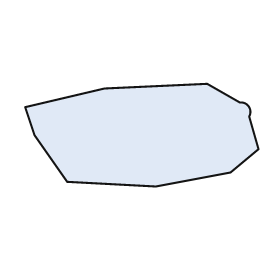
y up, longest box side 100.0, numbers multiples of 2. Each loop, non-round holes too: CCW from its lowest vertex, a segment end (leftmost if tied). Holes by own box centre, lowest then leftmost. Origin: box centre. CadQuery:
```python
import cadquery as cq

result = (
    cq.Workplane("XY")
    .moveTo(6.0, -22.0)
    .lineTo(38.0, -16.0)
    .lineTo(50.0, -6.0)
    .lineTo(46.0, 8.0)
    .threePointArc((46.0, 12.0), (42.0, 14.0))
    .lineTo(28.0, 22.0)
    .lineTo(-16.0, 20.0)
    .lineTo(-50.0, 12.0)
    .lineTo(-46.0, 0.0)
    .lineTo(-32.0, -20.0)
    .close()
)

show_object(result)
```